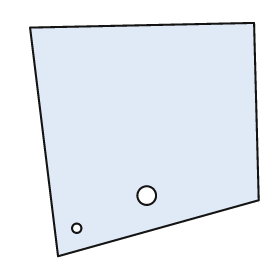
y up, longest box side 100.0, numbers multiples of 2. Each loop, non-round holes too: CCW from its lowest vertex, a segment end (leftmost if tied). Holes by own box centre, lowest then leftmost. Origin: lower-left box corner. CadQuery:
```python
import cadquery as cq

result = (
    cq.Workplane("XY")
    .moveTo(12.0, 0.0)
    .lineTo(98.0, 24.0)
    .lineTo(96.0, 100.0)
    .lineTo(0.0, 98.0)
    .close()
    .moveTo(20.0, 12.0)
    .circle(2.0)
    .moveTo(50.0, 26.0)
    .circle(4.0)
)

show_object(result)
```